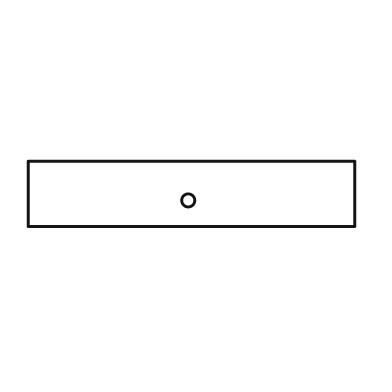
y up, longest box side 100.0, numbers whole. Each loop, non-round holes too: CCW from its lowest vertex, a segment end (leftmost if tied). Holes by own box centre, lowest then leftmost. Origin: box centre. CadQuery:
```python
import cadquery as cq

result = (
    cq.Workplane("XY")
    .moveTo(-50.0, -10.0)
    .lineTo(50.0, -10.0)
    .lineTo(50.0, 10.0)
    .lineTo(-50.0, 10.0)
    .close()
    .moveTo(-1.0, -2.0)
    .circle(2.0)
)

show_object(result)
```